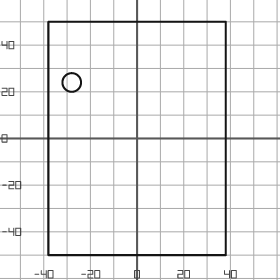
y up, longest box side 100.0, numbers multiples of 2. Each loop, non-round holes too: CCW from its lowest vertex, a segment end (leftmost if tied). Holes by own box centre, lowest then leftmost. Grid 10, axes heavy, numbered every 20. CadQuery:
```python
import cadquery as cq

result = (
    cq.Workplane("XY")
    .moveTo(-38.0, -50.0)
    .lineTo(38.0, -50.0)
    .lineTo(38.0, 50.0)
    .lineTo(-38.0, 50.0)
    .close()
    .moveTo(-28.0, 24.0)
    .circle(4.0)
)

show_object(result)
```